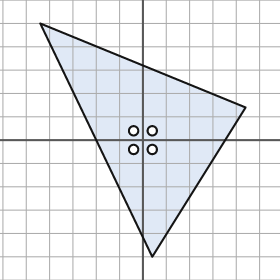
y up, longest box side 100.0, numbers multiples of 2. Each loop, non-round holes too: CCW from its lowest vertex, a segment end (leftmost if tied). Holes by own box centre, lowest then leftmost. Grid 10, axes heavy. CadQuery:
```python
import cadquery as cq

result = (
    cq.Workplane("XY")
    .moveTo(4.0, -50.0)
    .lineTo(44.0, 14.0)
    .lineTo(-44.0, 50.0)
    .close()
    .moveTo(-4.0, -4.0)
    .circle(2.0)
    .moveTo(4.0, -4.0)
    .circle(2.0)
    .moveTo(-4.0, 4.0)
    .circle(2.0)
    .moveTo(4.0, 4.0)
    .circle(2.0)
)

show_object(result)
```